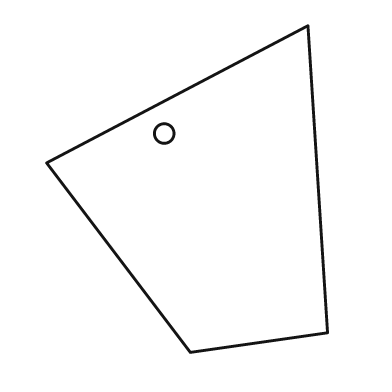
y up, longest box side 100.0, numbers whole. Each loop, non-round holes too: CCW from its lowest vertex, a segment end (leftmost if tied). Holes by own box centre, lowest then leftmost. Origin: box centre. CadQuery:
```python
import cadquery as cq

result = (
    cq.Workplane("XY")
    .moveTo(1.0, -50.0)
    .lineTo(43.0, -44.0)
    .lineTo(37.0, 50.0)
    .lineTo(-43.0, 8.0)
    .close()
    .moveTo(-7.0, 17.0)
    .circle(3.0)
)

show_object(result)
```